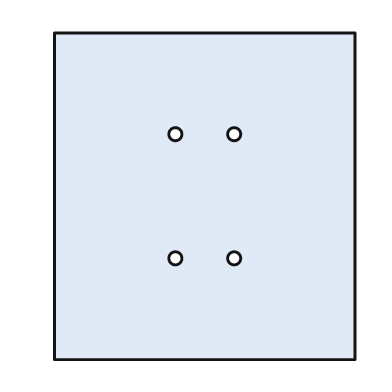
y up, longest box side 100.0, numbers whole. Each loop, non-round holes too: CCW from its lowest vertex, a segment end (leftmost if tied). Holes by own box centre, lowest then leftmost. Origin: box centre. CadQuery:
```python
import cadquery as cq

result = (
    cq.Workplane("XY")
    .moveTo(-46.0, -50.0)
    .lineTo(46.0, -50.0)
    .lineTo(46.0, 50.0)
    .lineTo(-46.0, 50.0)
    .close()
    .moveTo(-9.0, -19.0)
    .circle(2.0)
    .moveTo(9.0, -19.0)
    .circle(2.0)
    .moveTo(-9.0, 19.0)
    .circle(2.0)
    .moveTo(9.0, 19.0)
    .circle(2.0)
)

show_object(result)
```